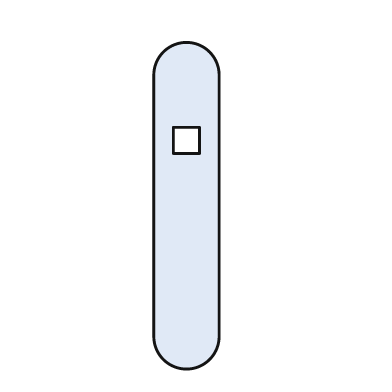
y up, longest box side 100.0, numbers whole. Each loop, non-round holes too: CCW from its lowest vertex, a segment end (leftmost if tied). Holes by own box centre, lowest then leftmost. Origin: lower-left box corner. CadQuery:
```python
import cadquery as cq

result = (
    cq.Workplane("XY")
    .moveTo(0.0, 10.0)
    .threePointArc((10.0, 0.0), (20.0, 10.0))
    .lineTo(20.0, 90.0)
    .threePointArc((10.0, 100.0), (0.0, 90.0))
    .close()
    .moveTo(6.0, 66.0)
    .lineTo(14.0, 66.0)
    .lineTo(14.0, 74.0)
    .lineTo(6.0, 74.0)
    .close()
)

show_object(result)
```